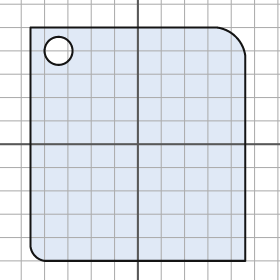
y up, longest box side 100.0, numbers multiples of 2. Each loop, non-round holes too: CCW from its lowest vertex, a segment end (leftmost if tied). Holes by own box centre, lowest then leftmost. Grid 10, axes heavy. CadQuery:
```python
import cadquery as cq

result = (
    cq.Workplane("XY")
    .moveTo(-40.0, -50.0)
    .lineTo(46.0, -50.0)
    .lineTo(46.0, 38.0)
    .threePointArc((42.0, 46.0), (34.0, 50.0))
    .lineTo(-46.0, 50.0)
    .lineTo(-46.0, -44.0)
    .threePointArc((-44.0, -48.0), (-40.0, -50.0))
    .close()
    .moveTo(-34.0, 40.0)
    .circle(6.0)
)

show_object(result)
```